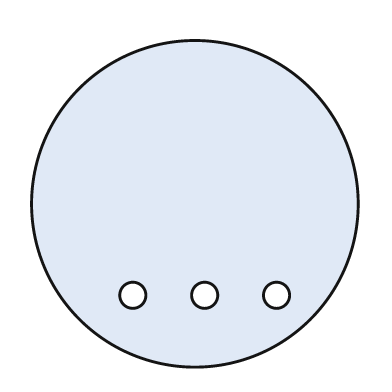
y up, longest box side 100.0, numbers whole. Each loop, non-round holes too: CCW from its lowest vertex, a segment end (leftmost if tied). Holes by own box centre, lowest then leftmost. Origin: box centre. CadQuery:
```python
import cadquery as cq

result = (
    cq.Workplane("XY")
    .moveTo(0.0, 0.0)
    .circle(50.0)
    .moveTo(-19.0, -28.0)
    .circle(4.0)
    .moveTo(3.0, -28.0)
    .circle(4.0)
    .moveTo(25.0, -28.0)
    .circle(4.0)
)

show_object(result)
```